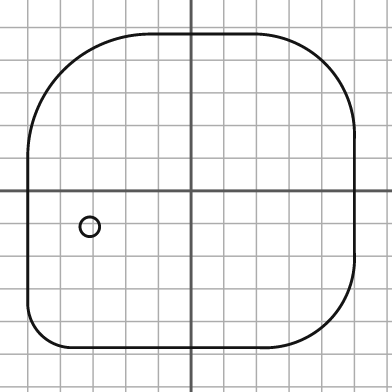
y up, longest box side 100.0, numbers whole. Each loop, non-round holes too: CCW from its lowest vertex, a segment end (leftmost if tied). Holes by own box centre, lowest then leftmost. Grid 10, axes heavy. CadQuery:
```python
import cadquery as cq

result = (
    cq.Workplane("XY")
    .moveTo(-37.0, -48.0)
    .lineTo(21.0, -48.0)
    .threePointArc((42.0, -40.0), (50.0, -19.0))
    .lineTo(50.0, 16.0)
    .threePointArc((41.0, 39.0), (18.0, 48.0))
    .lineTo(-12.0, 48.0)
    .threePointArc((-39.0, 37.0), (-50.0, 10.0))
    .lineTo(-50.0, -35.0)
    .threePointArc((-46.0, -44.0), (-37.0, -48.0))
    .close()
    .moveTo(-31.0, -11.0)
    .circle(3.0)
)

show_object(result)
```